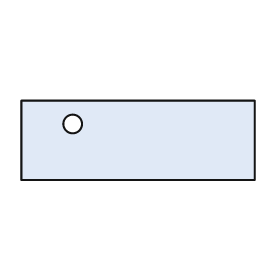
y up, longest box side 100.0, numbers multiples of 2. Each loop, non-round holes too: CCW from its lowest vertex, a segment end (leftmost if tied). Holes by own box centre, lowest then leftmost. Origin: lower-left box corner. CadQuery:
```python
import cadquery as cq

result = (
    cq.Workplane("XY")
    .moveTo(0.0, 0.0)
    .lineTo(100.0, 0.0)
    .lineTo(100.0, 34.0)
    .lineTo(0.0, 34.0)
    .close()
    .moveTo(22.0, 24.0)
    .circle(4.0)
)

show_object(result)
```